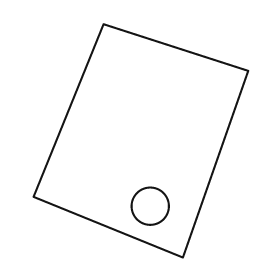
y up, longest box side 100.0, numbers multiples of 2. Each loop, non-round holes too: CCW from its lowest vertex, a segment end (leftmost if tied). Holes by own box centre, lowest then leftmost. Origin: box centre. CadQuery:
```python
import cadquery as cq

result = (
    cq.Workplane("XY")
    .moveTo(18.0, -50.0)
    .lineTo(46.0, 30.0)
    .lineTo(-16.0, 50.0)
    .lineTo(-46.0, -24.0)
    .close()
    .moveTo(4.0, -28.0)
    .circle(8.0)
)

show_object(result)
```